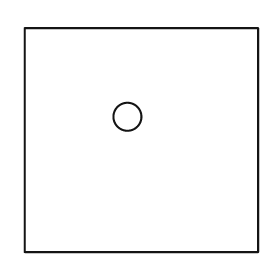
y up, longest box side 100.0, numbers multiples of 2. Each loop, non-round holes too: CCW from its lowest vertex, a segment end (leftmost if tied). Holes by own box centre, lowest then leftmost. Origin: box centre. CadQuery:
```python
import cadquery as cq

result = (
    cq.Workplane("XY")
    .moveTo(-50.0, -48.0)
    .lineTo(50.0, -48.0)
    .lineTo(50.0, 48.0)
    .lineTo(-50.0, 48.0)
    .close()
    .moveTo(-6.0, 10.0)
    .circle(6.0)
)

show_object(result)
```